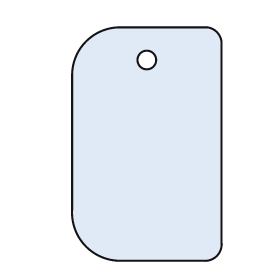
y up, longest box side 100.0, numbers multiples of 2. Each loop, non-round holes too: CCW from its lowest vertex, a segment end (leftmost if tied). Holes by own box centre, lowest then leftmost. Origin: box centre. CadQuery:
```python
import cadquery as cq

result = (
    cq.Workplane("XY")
    .moveTo(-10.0, -50.0)
    .lineTo(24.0, -50.0)
    .threePointArc((30.0, -48.0), (32.0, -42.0))
    .lineTo(32.0, 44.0)
    .threePointArc((30.0, 48.0), (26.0, 50.0))
    .lineTo(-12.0, 50.0)
    .threePointArc((-26.0, 44.0), (-32.0, 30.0))
    .lineTo(-32.0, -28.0)
    .threePointArc((-26.0, -44.0), (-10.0, -50.0))
    .close()
    .moveTo(0.0, 36.0)
    .circle(4.0)
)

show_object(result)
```